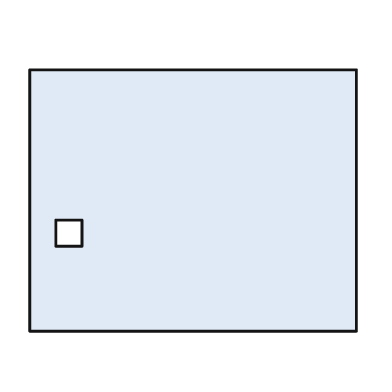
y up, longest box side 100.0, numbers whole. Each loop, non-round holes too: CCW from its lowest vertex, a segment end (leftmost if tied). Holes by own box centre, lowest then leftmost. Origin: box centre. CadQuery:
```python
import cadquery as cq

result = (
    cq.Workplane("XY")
    .moveTo(-50.0, -40.0)
    .lineTo(50.0, -40.0)
    .lineTo(50.0, 40.0)
    .lineTo(-50.0, 40.0)
    .close()
    .moveTo(-42.0, -14.0)
    .lineTo(-34.0, -14.0)
    .lineTo(-34.0, -6.0)
    .lineTo(-42.0, -6.0)
    .close()
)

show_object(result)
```